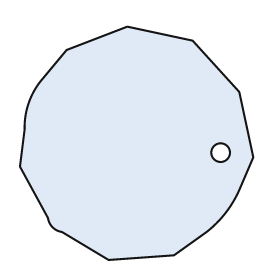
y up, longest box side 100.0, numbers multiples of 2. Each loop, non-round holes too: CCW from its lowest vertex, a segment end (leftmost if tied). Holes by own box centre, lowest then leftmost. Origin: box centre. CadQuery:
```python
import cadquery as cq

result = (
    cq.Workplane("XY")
    .moveTo(-12.0, -50.0)
    .lineTo(16.0, -48.0)
    .lineTo(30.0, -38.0)
    .threePointArc((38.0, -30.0), (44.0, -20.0))
    .lineTo(50.0, -6.0)
    .lineTo(44.0, 22.0)
    .lineTo(24.0, 44.0)
    .lineTo(-4.0, 50.0)
    .lineTo(-30.0, 40.0)
    .lineTo(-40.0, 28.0)
    .threePointArc((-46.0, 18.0), (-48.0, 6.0))
    .lineTo(-50.0, -10.0)
    .lineTo(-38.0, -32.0)
    .threePointArc((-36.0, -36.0), (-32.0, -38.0))
    .close()
    .moveTo(36.0, -4.0)
    .circle(4.0)
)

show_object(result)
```